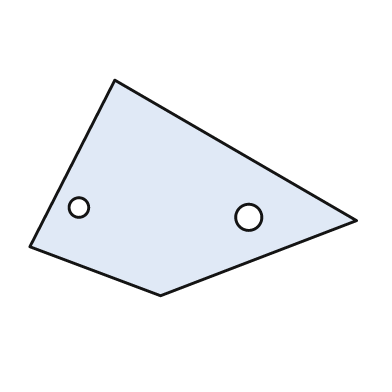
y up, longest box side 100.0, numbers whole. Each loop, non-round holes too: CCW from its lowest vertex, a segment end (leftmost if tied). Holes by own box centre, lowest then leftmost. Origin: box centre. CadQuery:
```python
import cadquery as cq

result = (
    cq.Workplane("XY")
    .moveTo(-10.0, -33.0)
    .lineTo(50.0, -10.0)
    .lineTo(-24.0, 33.0)
    .lineTo(-50.0, -18.0)
    .close()
    .moveTo(17.0, -9.0)
    .circle(4.0)
    .moveTo(-35.0, -6.0)
    .circle(3.0)
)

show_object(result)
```